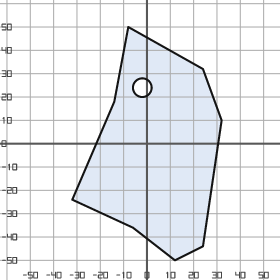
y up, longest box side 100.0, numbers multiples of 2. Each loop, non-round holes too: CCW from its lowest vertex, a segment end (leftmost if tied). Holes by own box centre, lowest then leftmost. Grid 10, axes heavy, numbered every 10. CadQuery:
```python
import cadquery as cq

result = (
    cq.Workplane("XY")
    .moveTo(12.0, -50.0)
    .lineTo(24.0, -44.0)
    .lineTo(32.0, 10.0)
    .lineTo(24.0, 32.0)
    .lineTo(-8.0, 50.0)
    .lineTo(-14.0, 18.0)
    .lineTo(-32.0, -24.0)
    .lineTo(-6.0, -36.0)
    .close()
    .moveTo(-2.0, 24.0)
    .circle(4.0)
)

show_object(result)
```